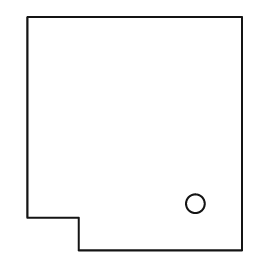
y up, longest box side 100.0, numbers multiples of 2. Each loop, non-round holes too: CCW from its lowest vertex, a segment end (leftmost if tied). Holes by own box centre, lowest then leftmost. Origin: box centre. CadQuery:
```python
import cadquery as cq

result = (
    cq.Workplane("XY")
    .moveTo(-24.0, -50.0)
    .lineTo(46.0, -50.0)
    .lineTo(46.0, 50.0)
    .lineTo(-46.0, 50.0)
    .lineTo(-46.0, -36.0)
    .lineTo(-24.0, -36.0)
    .close()
    .moveTo(26.0, -30.0)
    .circle(4.0)
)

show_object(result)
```